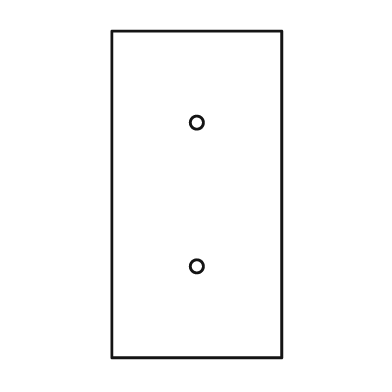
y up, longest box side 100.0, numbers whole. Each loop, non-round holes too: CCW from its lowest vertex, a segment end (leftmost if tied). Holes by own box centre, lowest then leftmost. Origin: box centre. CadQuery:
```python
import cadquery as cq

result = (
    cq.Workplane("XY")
    .moveTo(-26.0, -50.0)
    .lineTo(26.0, -50.0)
    .lineTo(26.0, 50.0)
    .lineTo(-26.0, 50.0)
    .close()
    .moveTo(0.0, -22.0)
    .circle(2.0)
    .moveTo(0.0, 22.0)
    .circle(2.0)
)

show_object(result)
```